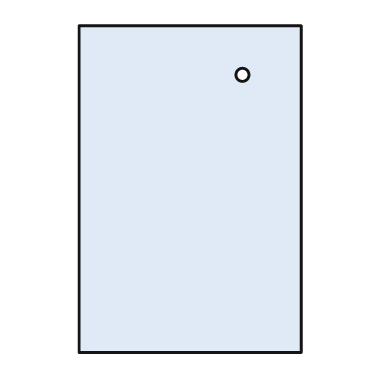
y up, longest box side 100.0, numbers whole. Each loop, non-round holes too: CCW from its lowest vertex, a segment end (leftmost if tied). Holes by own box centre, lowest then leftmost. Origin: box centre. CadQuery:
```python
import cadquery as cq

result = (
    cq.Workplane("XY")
    .moveTo(-34.0, -50.0)
    .lineTo(34.0, -50.0)
    .lineTo(34.0, 50.0)
    .lineTo(-34.0, 50.0)
    .close()
    .moveTo(16.0, 35.0)
    .circle(2.0)
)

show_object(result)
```